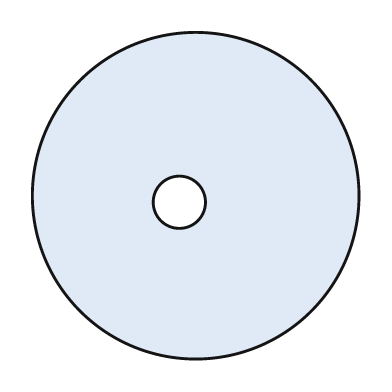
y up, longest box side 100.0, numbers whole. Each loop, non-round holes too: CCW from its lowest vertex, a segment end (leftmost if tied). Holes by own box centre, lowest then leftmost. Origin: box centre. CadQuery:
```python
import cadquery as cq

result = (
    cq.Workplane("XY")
    .moveTo(0.0, 0.0)
    .circle(50.0)
    .moveTo(-5.0, -2.0)
    .circle(8.0)
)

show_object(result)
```